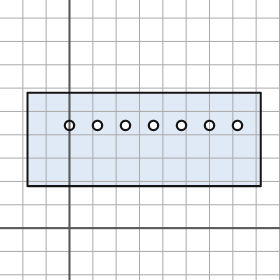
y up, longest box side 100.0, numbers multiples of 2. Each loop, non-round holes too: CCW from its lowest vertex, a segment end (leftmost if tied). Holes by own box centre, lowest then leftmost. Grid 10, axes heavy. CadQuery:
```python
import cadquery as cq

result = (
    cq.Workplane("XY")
    .moveTo(-18.0, 18.0)
    .lineTo(82.0, 18.0)
    .lineTo(82.0, 58.0)
    .lineTo(-18.0, 58.0)
    .close()
    .moveTo(0.0, 44.0)
    .circle(2.0)
    .moveTo(12.0, 44.0)
    .circle(2.0)
    .moveTo(24.0, 44.0)
    .circle(2.0)
    .moveTo(36.0, 44.0)
    .circle(2.0)
    .moveTo(48.0, 44.0)
    .circle(2.0)
    .moveTo(60.0, 44.0)
    .circle(2.0)
    .moveTo(72.0, 44.0)
    .circle(2.0)
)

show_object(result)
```